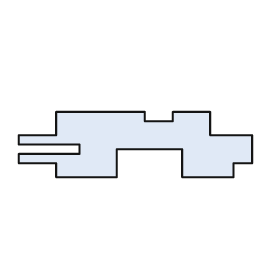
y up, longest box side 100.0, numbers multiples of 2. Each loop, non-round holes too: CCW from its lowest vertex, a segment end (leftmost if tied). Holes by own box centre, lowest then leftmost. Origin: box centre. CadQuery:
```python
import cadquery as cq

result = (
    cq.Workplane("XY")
    .moveTo(-34.0, -14.0)
    .lineTo(-8.0, -14.0)
    .lineTo(-8.0, -2.0)
    .lineTo(20.0, -2.0)
    .lineTo(20.0, -14.0)
    .lineTo(42.0, -14.0)
    .lineTo(42.0, -8.0)
    .lineTo(50.0, -8.0)
    .lineTo(50.0, 4.0)
    .lineTo(32.0, 4.0)
    .lineTo(32.0, 14.0)
    .lineTo(16.0, 14.0)
    .lineTo(16.0, 10.0)
    .lineTo(4.0, 10.0)
    .lineTo(4.0, 14.0)
    .lineTo(-34.0, 14.0)
    .lineTo(-34.0, 4.0)
    .lineTo(-50.0, 4.0)
    .lineTo(-50.0, 0.0)
    .lineTo(-24.0, 0.0)
    .lineTo(-24.0, -4.0)
    .lineTo(-50.0, -4.0)
    .lineTo(-50.0, -8.0)
    .lineTo(-34.0, -8.0)
    .close()
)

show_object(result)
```